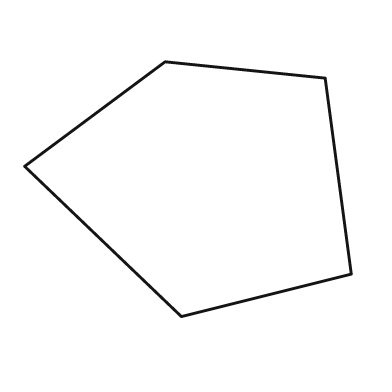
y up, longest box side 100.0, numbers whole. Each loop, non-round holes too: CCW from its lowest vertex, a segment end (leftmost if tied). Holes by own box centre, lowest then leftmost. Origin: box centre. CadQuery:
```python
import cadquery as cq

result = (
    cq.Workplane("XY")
    .moveTo(-2.0, -39.0)
    .lineTo(50.0, -26.0)
    .lineTo(42.0, 34.0)
    .lineTo(-7.0, 39.0)
    .lineTo(-50.0, 7.0)
    .close()
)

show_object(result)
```